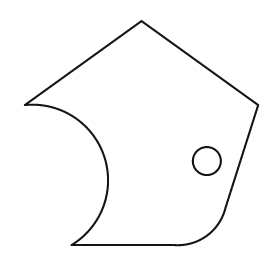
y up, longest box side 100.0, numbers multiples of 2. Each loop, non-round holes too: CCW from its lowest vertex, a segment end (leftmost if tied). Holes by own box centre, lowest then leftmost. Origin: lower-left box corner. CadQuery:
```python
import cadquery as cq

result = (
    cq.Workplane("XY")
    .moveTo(20.0, 0.0)
    .lineTo(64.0, 0.0)
    .threePointArc((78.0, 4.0), (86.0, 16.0))
    .lineTo(100.0, 60.0)
    .lineTo(50.0, 96.0)
    .lineTo(0.0, 60.0)
    .threePointArc((34.0, 38.0), (20.0, 0.0))
    .close()
    .moveTo(78.0, 36.0)
    .circle(6.0)
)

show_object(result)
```